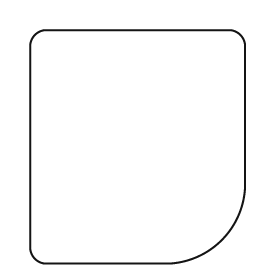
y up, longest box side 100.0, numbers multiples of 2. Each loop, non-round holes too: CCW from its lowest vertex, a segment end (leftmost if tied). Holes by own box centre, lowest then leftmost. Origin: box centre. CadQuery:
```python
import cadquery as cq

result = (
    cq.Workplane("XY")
    .moveTo(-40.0, -50.0)
    .lineTo(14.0, -50.0)
    .threePointArc((36.0, -40.0), (46.0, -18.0))
    .lineTo(46.0, 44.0)
    .threePointArc((44.0, 48.0), (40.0, 50.0))
    .lineTo(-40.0, 50.0)
    .threePointArc((-44.0, 48.0), (-46.0, 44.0))
    .lineTo(-46.0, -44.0)
    .threePointArc((-44.0, -48.0), (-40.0, -50.0))
    .close()
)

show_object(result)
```